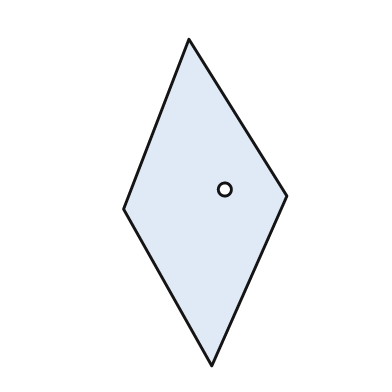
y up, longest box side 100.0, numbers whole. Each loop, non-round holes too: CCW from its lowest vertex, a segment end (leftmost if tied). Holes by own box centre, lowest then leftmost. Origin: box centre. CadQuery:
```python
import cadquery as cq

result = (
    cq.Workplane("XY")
    .moveTo(2.0, -50.0)
    .lineTo(25.0, 2.0)
    .lineTo(-5.0, 50.0)
    .lineTo(-25.0, -2.0)
    .close()
    .moveTo(6.0, 4.0)
    .circle(2.0)
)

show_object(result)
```